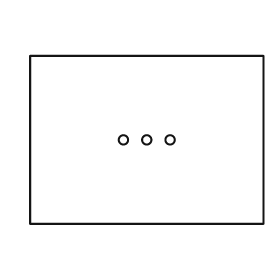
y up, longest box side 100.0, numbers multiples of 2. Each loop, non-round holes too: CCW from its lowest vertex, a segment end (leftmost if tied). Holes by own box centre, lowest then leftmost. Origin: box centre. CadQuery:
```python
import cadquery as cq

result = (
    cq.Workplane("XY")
    .moveTo(-50.0, -36.0)
    .lineTo(50.0, -36.0)
    .lineTo(50.0, 36.0)
    .lineTo(-50.0, 36.0)
    .close()
    .moveTo(-10.0, 0.0)
    .circle(2.0)
    .moveTo(0.0, 0.0)
    .circle(2.0)
    .moveTo(10.0, 0.0)
    .circle(2.0)
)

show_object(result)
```